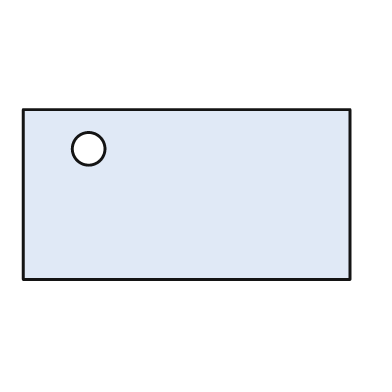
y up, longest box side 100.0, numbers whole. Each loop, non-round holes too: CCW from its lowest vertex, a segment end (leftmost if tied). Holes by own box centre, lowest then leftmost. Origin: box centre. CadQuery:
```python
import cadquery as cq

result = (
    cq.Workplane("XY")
    .moveTo(-50.0, -26.0)
    .lineTo(50.0, -26.0)
    .lineTo(50.0, 26.0)
    .lineTo(-50.0, 26.0)
    .close()
    .moveTo(-30.0, 14.0)
    .circle(5.0)
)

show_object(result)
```